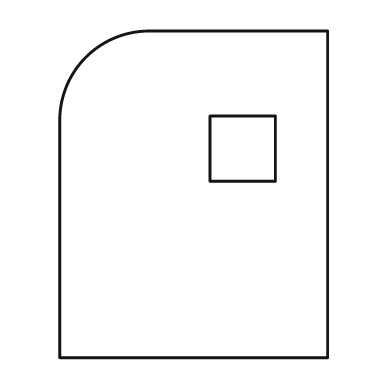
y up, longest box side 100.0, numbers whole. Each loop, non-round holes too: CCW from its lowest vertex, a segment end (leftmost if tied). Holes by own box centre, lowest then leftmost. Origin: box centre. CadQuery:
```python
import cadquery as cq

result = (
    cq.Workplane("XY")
    .moveTo(-41.0, -50.0)
    .lineTo(41.0, -50.0)
    .lineTo(41.0, 50.0)
    .lineTo(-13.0, 50.0)
    .threePointArc((-33.0, 42.0), (-41.0, 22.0))
    .close()
    .moveTo(5.0, 4.0)
    .lineTo(25.0, 4.0)
    .lineTo(25.0, 24.0)
    .lineTo(5.0, 24.0)
    .close()
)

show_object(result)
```